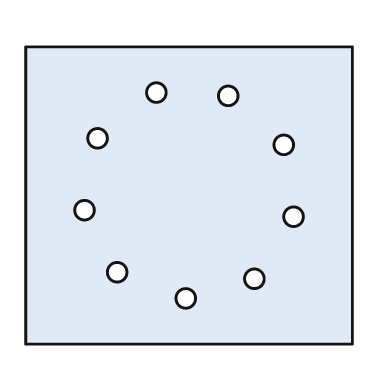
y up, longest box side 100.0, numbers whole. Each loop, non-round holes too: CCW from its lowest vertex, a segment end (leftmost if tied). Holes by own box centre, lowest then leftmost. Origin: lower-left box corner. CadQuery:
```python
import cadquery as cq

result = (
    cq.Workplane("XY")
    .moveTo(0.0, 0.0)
    .lineTo(100.0, 0.0)
    .lineTo(100.0, 91.0)
    .lineTo(0.0, 91.0)
    .close()
    .moveTo(49.0, 14.0)
    .circle(3.0)
    .moveTo(70.0, 20.0)
    .circle(3.0)
    .moveTo(28.0, 22.0)
    .circle(3.0)
    .moveTo(82.0, 39.0)
    .circle(3.0)
    .moveTo(18.0, 41.0)
    .circle(3.0)
    .moveTo(79.0, 61.0)
    .circle(3.0)
    .moveTo(22.0, 63.0)
    .circle(3.0)
    .moveTo(62.0, 76.0)
    .circle(3.0)
    .moveTo(40.0, 77.0)
    .circle(3.0)
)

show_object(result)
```